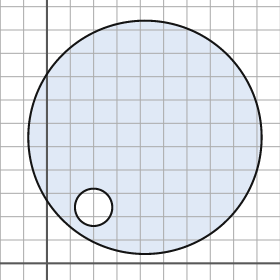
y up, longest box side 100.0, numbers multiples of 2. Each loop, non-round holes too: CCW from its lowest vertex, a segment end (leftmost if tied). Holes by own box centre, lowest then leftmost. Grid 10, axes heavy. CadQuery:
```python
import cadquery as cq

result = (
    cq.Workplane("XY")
    .moveTo(42.0, 54.0)
    .circle(50.0)
    .moveTo(20.0, 24.0)
    .circle(8.0)
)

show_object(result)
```